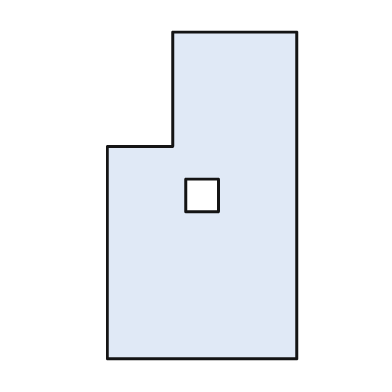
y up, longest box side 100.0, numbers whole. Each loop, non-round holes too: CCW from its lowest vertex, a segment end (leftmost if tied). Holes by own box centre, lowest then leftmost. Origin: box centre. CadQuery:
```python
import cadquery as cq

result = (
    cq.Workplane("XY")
    .moveTo(-29.0, -50.0)
    .lineTo(29.0, -50.0)
    .lineTo(29.0, 50.0)
    .lineTo(-9.0, 50.0)
    .lineTo(-9.0, 15.0)
    .lineTo(-29.0, 15.0)
    .close()
    .moveTo(-5.0, -5.0)
    .lineTo(5.0, -5.0)
    .lineTo(5.0, 5.0)
    .lineTo(-5.0, 5.0)
    .close()
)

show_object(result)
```